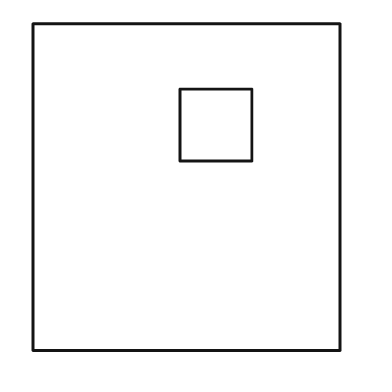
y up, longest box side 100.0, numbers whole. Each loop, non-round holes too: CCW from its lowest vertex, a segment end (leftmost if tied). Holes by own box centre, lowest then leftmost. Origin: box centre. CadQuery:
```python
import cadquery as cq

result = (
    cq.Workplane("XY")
    .moveTo(-47.0, -50.0)
    .lineTo(47.0, -50.0)
    .lineTo(47.0, 50.0)
    .lineTo(-47.0, 50.0)
    .close()
    .moveTo(-2.0, 8.0)
    .lineTo(20.0, 8.0)
    .lineTo(20.0, 30.0)
    .lineTo(-2.0, 30.0)
    .close()
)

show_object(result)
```